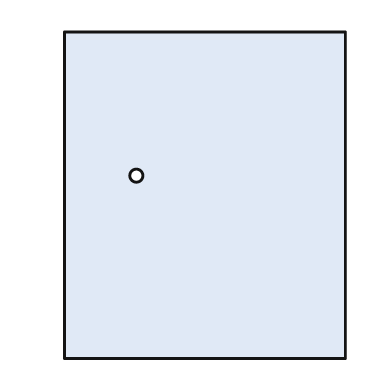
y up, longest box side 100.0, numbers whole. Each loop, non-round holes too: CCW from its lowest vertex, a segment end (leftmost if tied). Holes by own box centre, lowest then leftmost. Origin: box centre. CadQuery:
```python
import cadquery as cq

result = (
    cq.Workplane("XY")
    .moveTo(-43.0, -50.0)
    .lineTo(43.0, -50.0)
    .lineTo(43.0, 50.0)
    .lineTo(-43.0, 50.0)
    .close()
    .moveTo(-21.0, 6.0)
    .circle(2.0)
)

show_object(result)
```